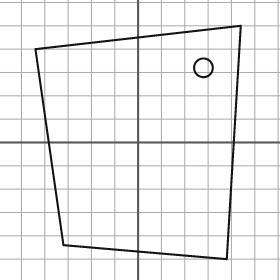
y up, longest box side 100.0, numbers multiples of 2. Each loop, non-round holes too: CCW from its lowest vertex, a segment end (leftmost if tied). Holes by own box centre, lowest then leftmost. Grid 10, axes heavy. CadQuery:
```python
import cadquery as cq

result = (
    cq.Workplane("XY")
    .moveTo(38.0, -50.0)
    .lineTo(44.0, 50.0)
    .lineTo(-44.0, 40.0)
    .lineTo(-32.0, -44.0)
    .close()
    .moveTo(28.0, 32.0)
    .circle(4.0)
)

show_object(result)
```